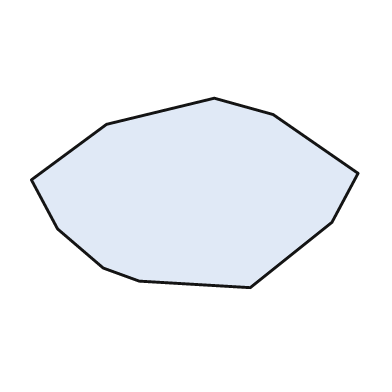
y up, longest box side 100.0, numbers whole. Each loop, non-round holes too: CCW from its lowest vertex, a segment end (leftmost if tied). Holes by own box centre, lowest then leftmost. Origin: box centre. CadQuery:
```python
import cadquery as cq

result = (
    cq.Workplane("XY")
    .moveTo(17.0, -29.0)
    .lineTo(42.0, -9.0)
    .lineTo(50.0, 6.0)
    .lineTo(24.0, 24.0)
    .lineTo(6.0, 29.0)
    .lineTo(-27.0, 21.0)
    .lineTo(-50.0, 4.0)
    .lineTo(-42.0, -11.0)
    .lineTo(-28.0, -23.0)
    .lineTo(-17.0, -27.0)
    .close()
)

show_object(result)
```